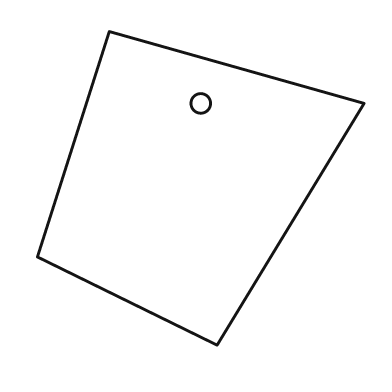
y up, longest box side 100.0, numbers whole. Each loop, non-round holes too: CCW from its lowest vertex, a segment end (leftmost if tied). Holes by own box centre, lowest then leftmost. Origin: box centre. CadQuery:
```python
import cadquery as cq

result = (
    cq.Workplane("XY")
    .moveTo(5.0, -48.0)
    .lineTo(50.0, 26.0)
    .lineTo(-28.0, 48.0)
    .lineTo(-50.0, -21.0)
    .close()
    .moveTo(0.0, 26.0)
    .circle(3.0)
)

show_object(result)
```